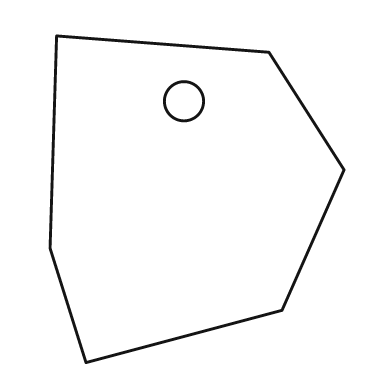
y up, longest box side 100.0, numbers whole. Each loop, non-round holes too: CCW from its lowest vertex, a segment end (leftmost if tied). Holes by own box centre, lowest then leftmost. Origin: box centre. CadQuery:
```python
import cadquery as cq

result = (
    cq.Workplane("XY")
    .moveTo(-34.0, -50.0)
    .lineTo(26.0, -34.0)
    .lineTo(45.0, 9.0)
    .lineTo(22.0, 45.0)
    .lineTo(-43.0, 50.0)
    .lineTo(-45.0, -15.0)
    .close()
    .moveTo(-4.0, 30.0)
    .circle(6.0)
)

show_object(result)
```